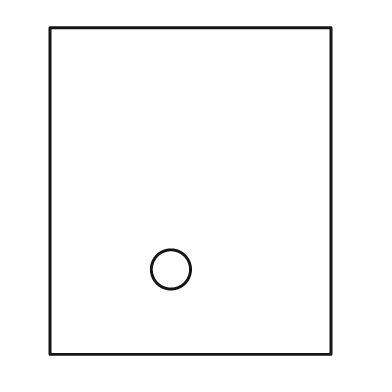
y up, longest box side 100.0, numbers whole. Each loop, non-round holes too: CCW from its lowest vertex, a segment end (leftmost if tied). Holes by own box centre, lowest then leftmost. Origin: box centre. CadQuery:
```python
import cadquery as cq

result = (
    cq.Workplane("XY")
    .moveTo(-43.0, -50.0)
    .lineTo(43.0, -50.0)
    .lineTo(43.0, 50.0)
    .lineTo(-43.0, 50.0)
    .close()
    .moveTo(-6.0, -24.0)
    .circle(6.0)
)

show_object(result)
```